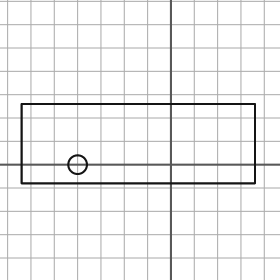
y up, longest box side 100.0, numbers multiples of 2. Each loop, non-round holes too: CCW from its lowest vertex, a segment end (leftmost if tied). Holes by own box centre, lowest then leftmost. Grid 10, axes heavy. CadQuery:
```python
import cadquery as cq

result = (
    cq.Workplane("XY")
    .moveTo(-64.0, -8.0)
    .lineTo(36.0, -8.0)
    .lineTo(36.0, 26.0)
    .lineTo(-64.0, 26.0)
    .close()
    .moveTo(-40.0, 0.0)
    .circle(4.0)
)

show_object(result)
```